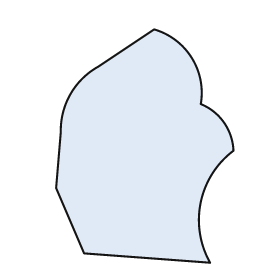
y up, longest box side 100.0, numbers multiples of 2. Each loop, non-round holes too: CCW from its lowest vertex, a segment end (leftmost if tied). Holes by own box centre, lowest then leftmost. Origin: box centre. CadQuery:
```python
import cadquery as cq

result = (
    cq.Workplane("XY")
    .moveTo(28.0, -50.0)
    .threePointArc((24.0, -24.0), (38.0, -2.0))
    .threePointArc((34.0, 10.0), (24.0, 18.0))
    .threePointArc((20.0, 38.0), (4.0, 50.0))
    .lineTo(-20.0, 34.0)
    .threePointArc((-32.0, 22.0), (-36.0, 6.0))
    .lineTo(-38.0, -18.0)
    .lineTo(-26.0, -46.0)
    .close()
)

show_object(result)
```